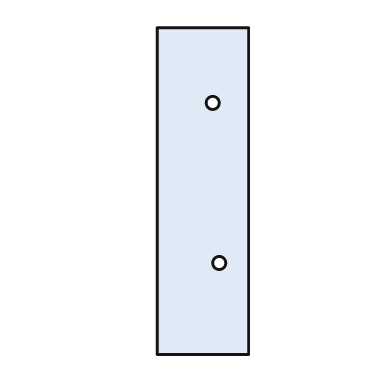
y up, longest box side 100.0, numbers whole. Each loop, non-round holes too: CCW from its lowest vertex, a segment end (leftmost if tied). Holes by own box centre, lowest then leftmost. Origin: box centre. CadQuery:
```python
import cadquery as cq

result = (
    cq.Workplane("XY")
    .moveTo(-14.0, -50.0)
    .lineTo(14.0, -50.0)
    .lineTo(14.0, 50.0)
    .lineTo(-14.0, 50.0)
    .close()
    .moveTo(5.0, -22.0)
    .circle(2.0)
    .moveTo(3.0, 27.0)
    .circle(2.0)
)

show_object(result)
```